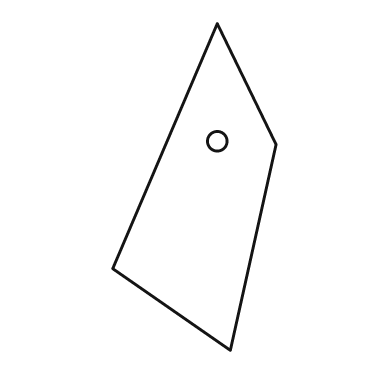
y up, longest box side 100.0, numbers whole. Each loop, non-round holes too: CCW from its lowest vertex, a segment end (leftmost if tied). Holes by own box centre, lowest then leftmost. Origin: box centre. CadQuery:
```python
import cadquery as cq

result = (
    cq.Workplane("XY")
    .moveTo(11.0, -50.0)
    .lineTo(25.0, 13.0)
    .lineTo(7.0, 50.0)
    .lineTo(-25.0, -25.0)
    .close()
    .moveTo(7.0, 14.0)
    .circle(3.0)
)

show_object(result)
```